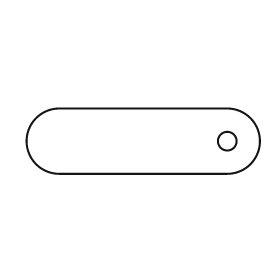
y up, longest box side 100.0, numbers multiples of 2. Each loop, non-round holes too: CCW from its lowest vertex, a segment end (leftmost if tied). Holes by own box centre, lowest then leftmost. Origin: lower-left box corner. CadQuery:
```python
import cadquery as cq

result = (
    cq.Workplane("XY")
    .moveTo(14.0, 0.0)
    .lineTo(86.0, 0.0)
    .threePointArc((100.0, 14.0), (86.0, 28.0))
    .lineTo(14.0, 28.0)
    .threePointArc((0.0, 14.0), (14.0, 0.0))
    .close()
    .moveTo(86.0, 14.0)
    .circle(4.0)
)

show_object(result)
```